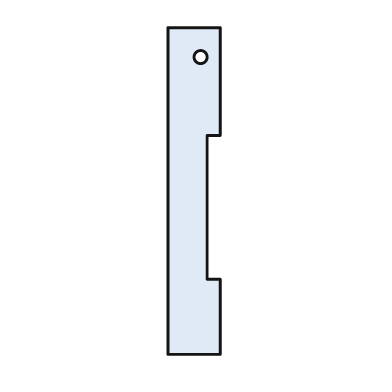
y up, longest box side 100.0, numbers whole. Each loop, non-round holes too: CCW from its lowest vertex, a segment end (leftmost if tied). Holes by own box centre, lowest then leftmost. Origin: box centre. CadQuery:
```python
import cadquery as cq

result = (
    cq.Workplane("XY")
    .moveTo(-8.0, -50.0)
    .lineTo(8.0, -50.0)
    .lineTo(8.0, -27.0)
    .lineTo(4.0, -27.0)
    .lineTo(4.0, 17.0)
    .lineTo(8.0, 17.0)
    .lineTo(8.0, 50.0)
    .lineTo(-8.0, 50.0)
    .close()
    .moveTo(2.0, 41.0)
    .circle(2.0)
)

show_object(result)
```